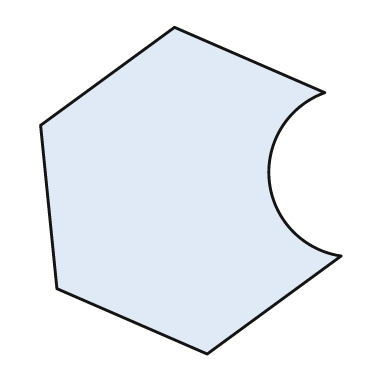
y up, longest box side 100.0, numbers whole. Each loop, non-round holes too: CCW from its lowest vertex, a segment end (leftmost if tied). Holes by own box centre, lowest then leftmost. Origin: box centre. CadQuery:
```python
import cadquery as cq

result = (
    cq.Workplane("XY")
    .moveTo(5.0, -50.0)
    .lineTo(46.0, -20.0)
    .threePointArc((24.0, 3.0), (41.0, 30.0))
    .lineTo(-5.0, 50.0)
    .lineTo(-46.0, 20.0)
    .lineTo(-41.0, -30.0)
    .close()
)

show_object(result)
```